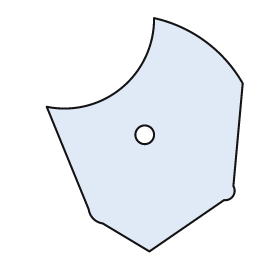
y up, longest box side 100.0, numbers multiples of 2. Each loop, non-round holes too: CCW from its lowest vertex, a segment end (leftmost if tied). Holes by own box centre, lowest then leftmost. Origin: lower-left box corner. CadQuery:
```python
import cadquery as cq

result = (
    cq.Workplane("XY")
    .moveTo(44.0, 0.0)
    .lineTo(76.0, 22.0)
    .threePointArc((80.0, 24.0), (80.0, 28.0))
    .lineTo(84.0, 72.0)
    .threePointArc((68.0, 90.0), (46.0, 100.0))
    .threePointArc((32.0, 70.0), (0.0, 62.0))
    .lineTo(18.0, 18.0)
    .threePointArc((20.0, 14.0), (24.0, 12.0))
    .close()
    .moveTo(42.0, 50.0)
    .circle(4.0)
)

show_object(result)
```